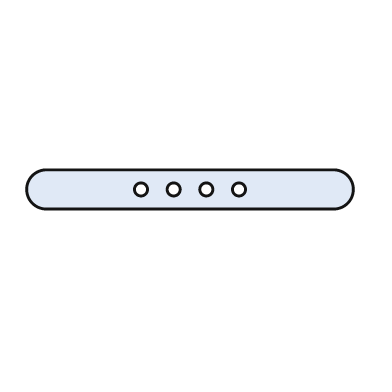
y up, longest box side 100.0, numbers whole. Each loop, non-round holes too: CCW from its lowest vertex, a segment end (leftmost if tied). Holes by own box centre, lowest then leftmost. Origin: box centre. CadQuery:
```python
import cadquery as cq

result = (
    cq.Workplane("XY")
    .moveTo(-44.0, -6.0)
    .lineTo(44.0, -6.0)
    .threePointArc((50.0, 0.0), (44.0, 6.0))
    .lineTo(-44.0, 6.0)
    .threePointArc((-50.0, 0.0), (-44.0, -6.0))
    .close()
    .moveTo(-15.0, 0.0)
    .circle(2.0)
    .moveTo(-5.0, 0.0)
    .circle(2.0)
    .moveTo(5.0, 0.0)
    .circle(2.0)
    .moveTo(15.0, 0.0)
    .circle(2.0)
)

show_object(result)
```